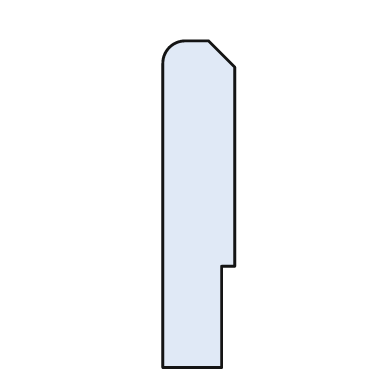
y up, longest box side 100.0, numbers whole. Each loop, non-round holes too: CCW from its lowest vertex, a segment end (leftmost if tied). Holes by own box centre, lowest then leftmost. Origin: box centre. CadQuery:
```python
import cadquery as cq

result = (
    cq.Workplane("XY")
    .moveTo(-11.0, -50.0)
    .lineTo(7.0, -50.0)
    .lineTo(7.0, -19.0)
    .lineTo(11.0, -19.0)
    .lineTo(11.0, 42.0)
    .lineTo(3.0, 50.0)
    .lineTo(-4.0, 50.0)
    .threePointArc((-9.0, 48.0), (-11.0, 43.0))
    .close()
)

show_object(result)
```